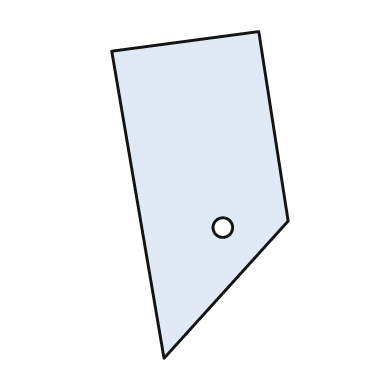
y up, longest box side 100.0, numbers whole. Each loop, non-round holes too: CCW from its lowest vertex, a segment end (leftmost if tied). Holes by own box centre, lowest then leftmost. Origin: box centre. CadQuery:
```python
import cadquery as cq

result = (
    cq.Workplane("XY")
    .moveTo(-11.0, -50.0)
    .lineTo(27.0, -8.0)
    .lineTo(18.0, 50.0)
    .lineTo(-27.0, 44.0)
    .close()
    .moveTo(7.0, -10.0)
    .circle(3.0)
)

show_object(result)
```